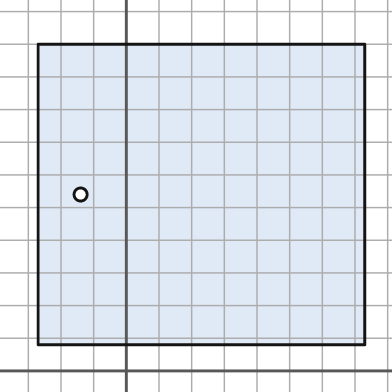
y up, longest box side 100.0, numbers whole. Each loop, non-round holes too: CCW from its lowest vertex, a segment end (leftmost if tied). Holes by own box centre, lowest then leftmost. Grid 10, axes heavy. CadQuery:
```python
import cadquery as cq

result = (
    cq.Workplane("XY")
    .moveTo(-27.0, 8.0)
    .lineTo(73.0, 8.0)
    .lineTo(73.0, 100.0)
    .lineTo(-27.0, 100.0)
    .close()
    .moveTo(-14.0, 54.0)
    .circle(2.0)
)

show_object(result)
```